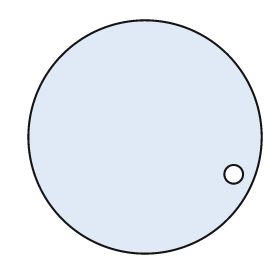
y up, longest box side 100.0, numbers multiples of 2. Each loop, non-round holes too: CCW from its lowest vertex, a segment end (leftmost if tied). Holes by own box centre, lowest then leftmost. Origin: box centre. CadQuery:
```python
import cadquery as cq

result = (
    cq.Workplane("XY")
    .moveTo(0.0, 0.0)
    .circle(50.0)
    .moveTo(38.0, -16.0)
    .circle(4.0)
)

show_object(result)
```